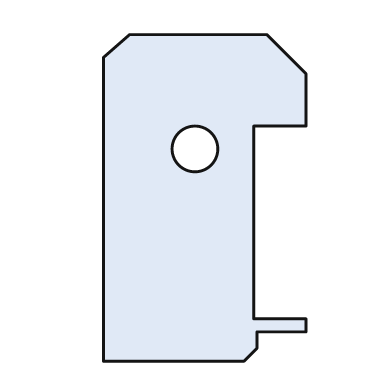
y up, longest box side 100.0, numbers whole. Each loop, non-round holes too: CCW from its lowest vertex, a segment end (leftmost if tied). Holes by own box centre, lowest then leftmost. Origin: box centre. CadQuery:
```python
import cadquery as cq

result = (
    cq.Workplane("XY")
    .moveTo(-31.0, -50.0)
    .lineTo(12.0, -50.0)
    .lineTo(16.0, -46.0)
    .lineTo(16.0, -41.0)
    .lineTo(31.0, -41.0)
    .lineTo(31.0, -37.0)
    .lineTo(15.0, -37.0)
    .lineTo(15.0, 22.0)
    .lineTo(31.0, 22.0)
    .lineTo(31.0, 38.0)
    .lineTo(19.0, 50.0)
    .lineTo(-23.0, 50.0)
    .lineTo(-31.0, 43.0)
    .close()
    .moveTo(-3.0, 15.0)
    .circle(7.0)
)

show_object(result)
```